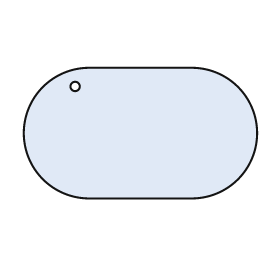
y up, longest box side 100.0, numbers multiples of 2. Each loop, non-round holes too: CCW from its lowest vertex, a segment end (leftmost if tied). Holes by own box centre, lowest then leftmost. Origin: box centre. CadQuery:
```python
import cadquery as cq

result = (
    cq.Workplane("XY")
    .moveTo(-22.0, -28.0)
    .lineTo(22.0, -28.0)
    .threePointArc((50.0, 0.0), (22.0, 28.0))
    .lineTo(-22.0, 28.0)
    .threePointArc((-50.0, 0.0), (-22.0, -28.0))
    .close()
    .moveTo(-28.0, 20.0)
    .circle(2.0)
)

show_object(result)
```